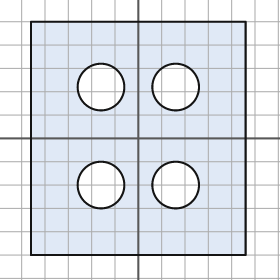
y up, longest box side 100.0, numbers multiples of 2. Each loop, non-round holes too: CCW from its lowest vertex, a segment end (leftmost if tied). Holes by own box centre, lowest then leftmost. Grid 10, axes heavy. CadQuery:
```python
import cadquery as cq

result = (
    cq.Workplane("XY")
    .moveTo(-46.0, -50.0)
    .lineTo(46.0, -50.0)
    .lineTo(46.0, 50.0)
    .lineTo(-46.0, 50.0)
    .close()
    .moveTo(-16.0, -20.0)
    .circle(10.0)
    .moveTo(16.0, -20.0)
    .circle(10.0)
    .moveTo(-16.0, 22.0)
    .circle(10.0)
    .moveTo(16.0, 22.0)
    .circle(10.0)
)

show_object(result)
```